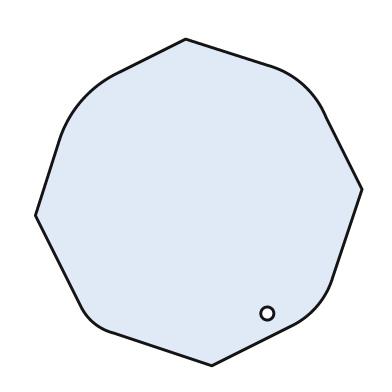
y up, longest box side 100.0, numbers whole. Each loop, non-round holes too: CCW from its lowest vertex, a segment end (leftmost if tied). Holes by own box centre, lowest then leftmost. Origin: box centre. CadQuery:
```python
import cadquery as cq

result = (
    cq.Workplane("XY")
    .moveTo(4.0, -50.0)
    .lineTo(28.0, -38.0)
    .threePointArc((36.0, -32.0), (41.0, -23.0))
    .lineTo(50.0, 4.0)
    .lineTo(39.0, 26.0)
    .threePointArc((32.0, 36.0), (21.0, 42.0))
    .lineTo(-4.0, 50.0)
    .lineTo(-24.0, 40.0)
    .threePointArc((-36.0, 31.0), (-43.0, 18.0))
    .lineTo(-50.0, -4.0)
    .lineTo(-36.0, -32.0)
    .threePointArc((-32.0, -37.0), (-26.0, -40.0))
    .close()
    .moveTo(21.0, -34.0)
    .circle(2.0)
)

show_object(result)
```